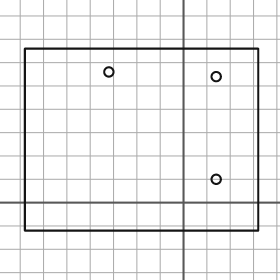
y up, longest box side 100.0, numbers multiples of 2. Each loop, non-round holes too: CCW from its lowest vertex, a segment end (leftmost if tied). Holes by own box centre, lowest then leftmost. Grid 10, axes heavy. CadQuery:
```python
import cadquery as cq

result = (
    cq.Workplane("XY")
    .moveTo(-68.0, -12.0)
    .lineTo(32.0, -12.0)
    .lineTo(32.0, 66.0)
    .lineTo(-68.0, 66.0)
    .close()
    .moveTo(14.0, 10.0)
    .circle(2.0)
    .moveTo(14.0, 54.0)
    .circle(2.0)
    .moveTo(-32.0, 56.0)
    .circle(2.0)
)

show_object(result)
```